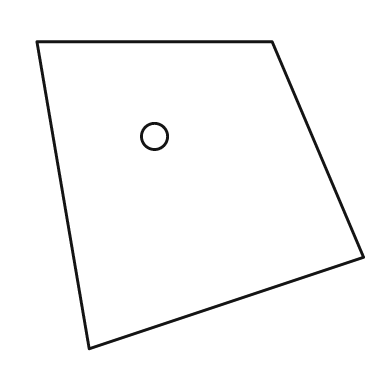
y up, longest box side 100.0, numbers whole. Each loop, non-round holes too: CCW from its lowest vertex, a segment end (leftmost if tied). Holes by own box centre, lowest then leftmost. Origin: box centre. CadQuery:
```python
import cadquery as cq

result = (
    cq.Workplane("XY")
    .moveTo(-34.0, -47.0)
    .lineTo(50.0, -19.0)
    .lineTo(22.0, 47.0)
    .lineTo(-50.0, 47.0)
    .close()
    .moveTo(-14.0, 18.0)
    .circle(4.0)
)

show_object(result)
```